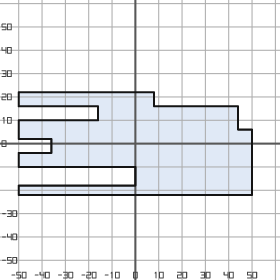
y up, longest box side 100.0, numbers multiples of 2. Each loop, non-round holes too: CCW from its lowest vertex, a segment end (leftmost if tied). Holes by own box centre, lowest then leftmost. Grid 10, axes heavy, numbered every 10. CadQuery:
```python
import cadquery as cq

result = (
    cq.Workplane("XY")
    .moveTo(-50.0, -22.0)
    .lineTo(50.0, -22.0)
    .lineTo(50.0, 6.0)
    .lineTo(44.0, 6.0)
    .lineTo(44.0, 16.0)
    .lineTo(8.0, 16.0)
    .lineTo(8.0, 22.0)
    .lineTo(-50.0, 22.0)
    .lineTo(-50.0, 16.0)
    .lineTo(-16.0, 16.0)
    .lineTo(-16.0, 10.0)
    .lineTo(-50.0, 10.0)
    .lineTo(-50.0, 2.0)
    .lineTo(-36.0, 2.0)
    .lineTo(-36.0, -4.0)
    .lineTo(-50.0, -4.0)
    .lineTo(-50.0, -10.0)
    .lineTo(0.0, -10.0)
    .lineTo(0.0, -18.0)
    .lineTo(-50.0, -18.0)
    .close()
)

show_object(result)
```